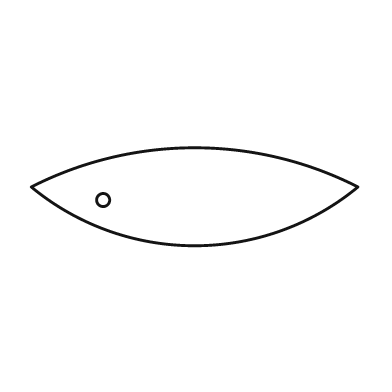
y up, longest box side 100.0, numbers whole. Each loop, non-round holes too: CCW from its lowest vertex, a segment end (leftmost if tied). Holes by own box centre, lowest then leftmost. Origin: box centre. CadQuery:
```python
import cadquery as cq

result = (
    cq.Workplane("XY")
    .moveTo(-50.0, 3.0)
    .threePointArc((0.0, -15.0), (50.0, 3.0))
    .threePointArc((0.0, 15.0), (-50.0, 3.0))
    .close()
    .moveTo(-28.0, -1.0)
    .circle(2.0)
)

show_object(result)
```